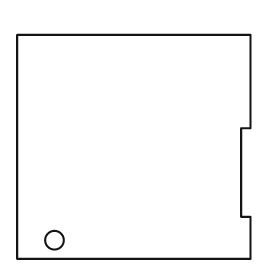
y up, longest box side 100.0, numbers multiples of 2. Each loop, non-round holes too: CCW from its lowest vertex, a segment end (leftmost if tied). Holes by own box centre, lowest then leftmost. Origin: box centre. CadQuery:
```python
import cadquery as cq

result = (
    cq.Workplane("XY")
    .moveTo(-50.0, -48.0)
    .lineTo(50.0, -48.0)
    .lineTo(50.0, -30.0)
    .lineTo(46.0, -30.0)
    .lineTo(46.0, 8.0)
    .lineTo(50.0, 8.0)
    .lineTo(50.0, 48.0)
    .lineTo(-50.0, 48.0)
    .close()
    .moveTo(-34.0, -40.0)
    .circle(4.0)
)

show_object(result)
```